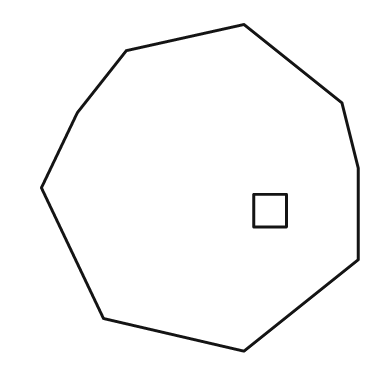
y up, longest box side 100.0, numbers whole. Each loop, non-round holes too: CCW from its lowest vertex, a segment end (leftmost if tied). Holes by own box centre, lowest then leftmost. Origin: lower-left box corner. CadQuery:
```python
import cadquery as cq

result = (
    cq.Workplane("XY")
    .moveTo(62.0, 0.0)
    .lineTo(97.0, 28.0)
    .lineTo(97.0, 56.0)
    .lineTo(92.0, 76.0)
    .lineTo(62.0, 100.0)
    .lineTo(26.0, 92.0)
    .lineTo(11.0, 73.0)
    .lineTo(0.0, 50.0)
    .lineTo(19.0, 10.0)
    .close()
    .moveTo(65.0, 38.0)
    .lineTo(75.0, 38.0)
    .lineTo(75.0, 48.0)
    .lineTo(65.0, 48.0)
    .close()
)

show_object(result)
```